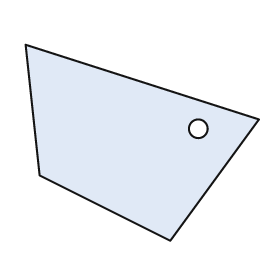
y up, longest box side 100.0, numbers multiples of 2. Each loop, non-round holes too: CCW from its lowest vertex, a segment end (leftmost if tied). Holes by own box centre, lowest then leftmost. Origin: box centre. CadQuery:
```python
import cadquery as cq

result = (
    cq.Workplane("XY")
    .moveTo(12.0, -42.0)
    .lineTo(50.0, 10.0)
    .lineTo(-50.0, 42.0)
    .lineTo(-44.0, -14.0)
    .close()
    .moveTo(24.0, 6.0)
    .circle(4.0)
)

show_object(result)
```